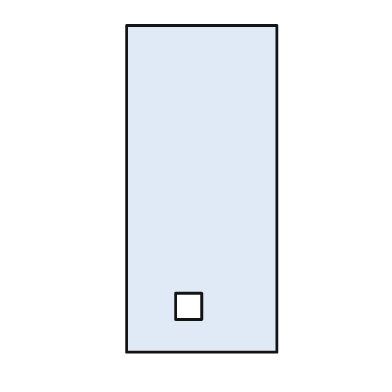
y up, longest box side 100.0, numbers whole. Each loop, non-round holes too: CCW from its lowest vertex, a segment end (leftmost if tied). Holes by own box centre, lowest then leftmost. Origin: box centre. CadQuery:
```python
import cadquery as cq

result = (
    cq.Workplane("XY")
    .moveTo(-23.0, -50.0)
    .lineTo(23.0, -50.0)
    .lineTo(23.0, 50.0)
    .lineTo(-23.0, 50.0)
    .close()
    .moveTo(-8.0, -40.0)
    .lineTo(0.0, -40.0)
    .lineTo(0.0, -32.0)
    .lineTo(-8.0, -32.0)
    .close()
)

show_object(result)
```